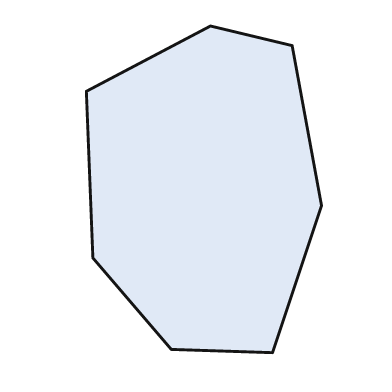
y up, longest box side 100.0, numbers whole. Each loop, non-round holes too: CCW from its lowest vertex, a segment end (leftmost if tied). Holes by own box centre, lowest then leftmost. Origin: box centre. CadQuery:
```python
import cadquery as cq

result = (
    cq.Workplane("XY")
    .moveTo(21.0, -50.0)
    .lineTo(36.0, -5.0)
    .lineTo(27.0, 44.0)
    .lineTo(2.0, 50.0)
    .lineTo(-36.0, 30.0)
    .lineTo(-34.0, -21.0)
    .lineTo(-10.0, -49.0)
    .close()
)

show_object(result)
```